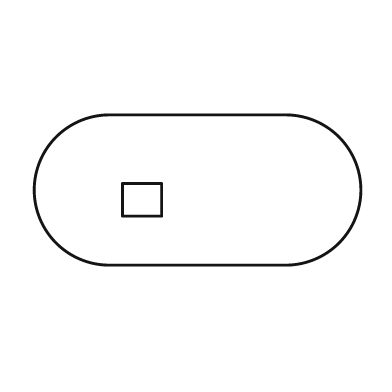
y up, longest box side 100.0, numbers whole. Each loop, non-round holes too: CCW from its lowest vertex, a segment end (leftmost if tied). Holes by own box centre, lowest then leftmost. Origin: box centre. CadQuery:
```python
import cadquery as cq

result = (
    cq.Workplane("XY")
    .moveTo(-27.0, -23.0)
    .lineTo(27.0, -23.0)
    .threePointArc((50.0, 0.0), (27.0, 23.0))
    .lineTo(-27.0, 23.0)
    .threePointArc((-50.0, 0.0), (-27.0, -23.0))
    .close()
    .moveTo(-23.0, -8.0)
    .lineTo(-11.0, -8.0)
    .lineTo(-11.0, 2.0)
    .lineTo(-23.0, 2.0)
    .close()
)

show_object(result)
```